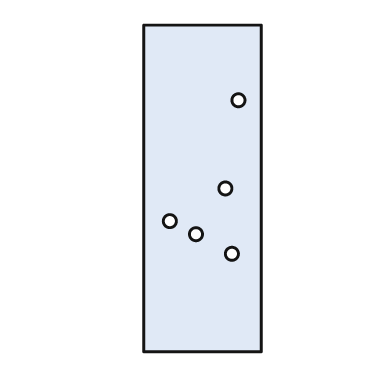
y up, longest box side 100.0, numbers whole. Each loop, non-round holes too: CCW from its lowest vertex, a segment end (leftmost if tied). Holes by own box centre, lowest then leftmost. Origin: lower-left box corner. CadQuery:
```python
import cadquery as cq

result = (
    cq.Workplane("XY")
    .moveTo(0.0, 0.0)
    .lineTo(36.0, 0.0)
    .lineTo(36.0, 100.0)
    .lineTo(0.0, 100.0)
    .close()
    .moveTo(27.0, 30.0)
    .circle(2.0)
    .moveTo(16.0, 36.0)
    .circle(2.0)
    .moveTo(8.0, 40.0)
    .circle(2.0)
    .moveTo(25.0, 50.0)
    .circle(2.0)
    .moveTo(29.0, 77.0)
    .circle(2.0)
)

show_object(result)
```